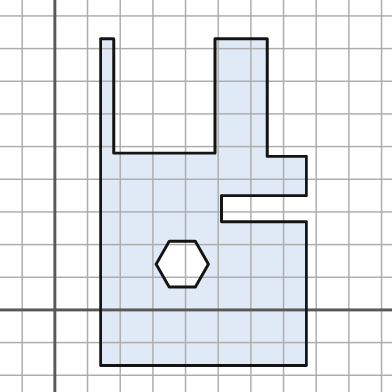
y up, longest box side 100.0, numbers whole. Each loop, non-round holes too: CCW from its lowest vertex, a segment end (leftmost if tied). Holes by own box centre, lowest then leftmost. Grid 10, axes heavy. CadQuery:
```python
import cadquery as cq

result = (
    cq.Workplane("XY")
    .moveTo(14.0, -17.0)
    .lineTo(77.0, -17.0)
    .lineTo(77.0, 27.0)
    .lineTo(51.0, 27.0)
    .lineTo(51.0, 35.0)
    .lineTo(77.0, 35.0)
    .lineTo(77.0, 47.0)
    .lineTo(65.0, 47.0)
    .lineTo(65.0, 83.0)
    .lineTo(49.0, 83.0)
    .lineTo(49.0, 48.0)
    .lineTo(18.0, 48.0)
    .lineTo(18.0, 83.0)
    .lineTo(14.0, 83.0)
    .close()
    .moveTo(35.0, 7.0)
    .lineTo(43.0, 7.0)
    .lineTo(47.0, 14.0)
    .lineTo(43.0, 21.0)
    .lineTo(35.0, 21.0)
    .lineTo(31.0, 14.0)
    .close()
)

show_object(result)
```